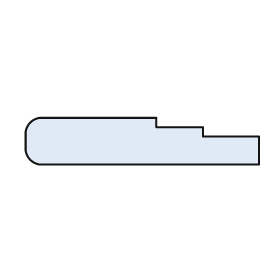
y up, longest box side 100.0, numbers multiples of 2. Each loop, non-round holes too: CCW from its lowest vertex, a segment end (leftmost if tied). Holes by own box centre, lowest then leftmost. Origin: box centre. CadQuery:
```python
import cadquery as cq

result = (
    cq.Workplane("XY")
    .moveTo(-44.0, -10.0)
    .lineTo(50.0, -10.0)
    .lineTo(50.0, 2.0)
    .lineTo(26.0, 2.0)
    .lineTo(26.0, 6.0)
    .lineTo(6.0, 6.0)
    .lineTo(6.0, 10.0)
    .lineTo(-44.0, 10.0)
    .threePointArc((-48.0, 8.0), (-50.0, 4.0))
    .lineTo(-50.0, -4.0)
    .threePointArc((-48.0, -8.0), (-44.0, -10.0))
    .close()
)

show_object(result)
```